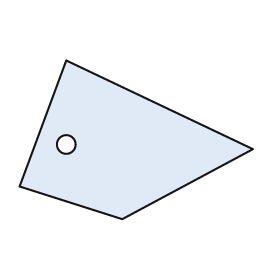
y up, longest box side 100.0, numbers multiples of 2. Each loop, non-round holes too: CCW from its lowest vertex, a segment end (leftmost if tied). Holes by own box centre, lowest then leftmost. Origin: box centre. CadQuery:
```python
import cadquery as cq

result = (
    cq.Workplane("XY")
    .moveTo(-6.0, -34.0)
    .lineTo(50.0, -4.0)
    .lineTo(-30.0, 34.0)
    .lineTo(-50.0, -20.0)
    .close()
    .moveTo(-30.0, -2.0)
    .circle(4.0)
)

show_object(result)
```